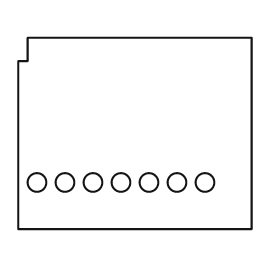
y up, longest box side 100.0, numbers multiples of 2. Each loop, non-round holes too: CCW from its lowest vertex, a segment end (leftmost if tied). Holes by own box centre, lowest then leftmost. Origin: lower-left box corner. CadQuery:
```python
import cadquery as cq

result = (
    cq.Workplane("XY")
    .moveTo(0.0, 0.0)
    .lineTo(100.0, 0.0)
    .lineTo(100.0, 82.0)
    .lineTo(4.0, 82.0)
    .lineTo(4.0, 72.0)
    .lineTo(0.0, 72.0)
    .close()
    .moveTo(8.0, 20.0)
    .circle(4.0)
    .moveTo(20.0, 20.0)
    .circle(4.0)
    .moveTo(32.0, 20.0)
    .circle(4.0)
    .moveTo(44.0, 20.0)
    .circle(4.0)
    .moveTo(56.0, 20.0)
    .circle(4.0)
    .moveTo(68.0, 20.0)
    .circle(4.0)
    .moveTo(80.0, 20.0)
    .circle(4.0)
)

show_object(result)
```